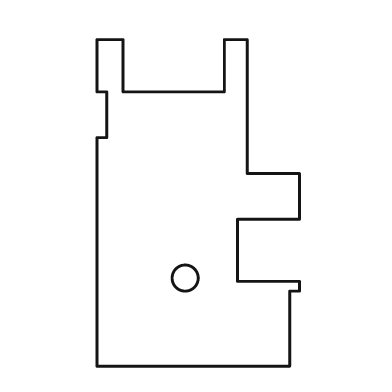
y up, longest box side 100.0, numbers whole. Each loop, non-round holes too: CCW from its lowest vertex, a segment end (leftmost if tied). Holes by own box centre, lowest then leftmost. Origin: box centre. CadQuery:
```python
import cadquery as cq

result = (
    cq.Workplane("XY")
    .moveTo(-31.0, -50.0)
    .lineTo(28.0, -50.0)
    .lineTo(28.0, -27.0)
    .lineTo(31.0, -27.0)
    .lineTo(31.0, -24.0)
    .lineTo(12.0, -24.0)
    .lineTo(12.0, -5.0)
    .lineTo(31.0, -5.0)
    .lineTo(31.0, 9.0)
    .lineTo(15.0, 9.0)
    .lineTo(15.0, 50.0)
    .lineTo(8.0, 50.0)
    .lineTo(8.0, 34.0)
    .lineTo(-23.0, 34.0)
    .lineTo(-23.0, 50.0)
    .lineTo(-31.0, 50.0)
    .lineTo(-31.0, 34.0)
    .lineTo(-28.0, 34.0)
    .lineTo(-28.0, 20.0)
    .lineTo(-31.0, 20.0)
    .close()
    .moveTo(-4.0, -23.0)
    .circle(4.0)
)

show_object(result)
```